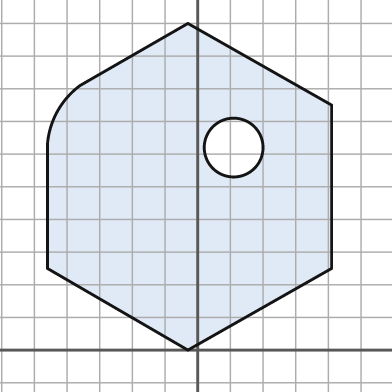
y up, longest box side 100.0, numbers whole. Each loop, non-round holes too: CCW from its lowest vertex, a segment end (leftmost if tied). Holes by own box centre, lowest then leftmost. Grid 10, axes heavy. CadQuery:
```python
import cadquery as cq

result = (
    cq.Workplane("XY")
    .moveTo(-3.0, 0.0)
    .lineTo(41.0, 25.0)
    .lineTo(41.0, 75.0)
    .lineTo(-3.0, 100.0)
    .lineTo(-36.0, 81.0)
    .threePointArc((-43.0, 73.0), (-46.0, 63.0))
    .lineTo(-46.0, 25.0)
    .close()
    .moveTo(11.0, 62.0)
    .circle(9.0)
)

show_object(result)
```